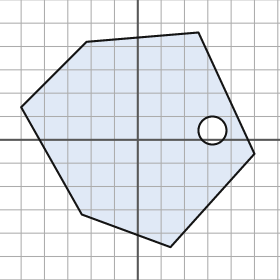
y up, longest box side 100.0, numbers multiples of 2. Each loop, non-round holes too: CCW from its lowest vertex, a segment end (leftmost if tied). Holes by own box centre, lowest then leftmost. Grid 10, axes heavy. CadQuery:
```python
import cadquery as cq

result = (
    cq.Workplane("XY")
    .moveTo(14.0, -46.0)
    .lineTo(50.0, -6.0)
    .lineTo(26.0, 46.0)
    .lineTo(-22.0, 42.0)
    .lineTo(-50.0, 14.0)
    .lineTo(-24.0, -32.0)
    .close()
    .moveTo(32.0, 4.0)
    .circle(6.0)
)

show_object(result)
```